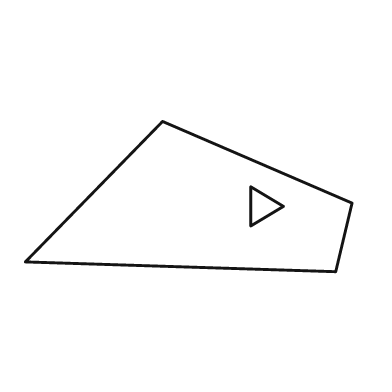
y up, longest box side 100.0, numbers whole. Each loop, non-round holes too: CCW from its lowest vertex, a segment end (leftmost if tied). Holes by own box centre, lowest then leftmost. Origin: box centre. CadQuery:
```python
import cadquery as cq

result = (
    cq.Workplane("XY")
    .moveTo(45.0, -23.0)
    .lineTo(50.0, -2.0)
    .lineTo(-8.0, 23.0)
    .lineTo(-50.0, -20.0)
    .close()
    .moveTo(19.0, -9.0)
    .lineTo(29.0, -3.0)
    .lineTo(19.0, 3.0)
    .close()
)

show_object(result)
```